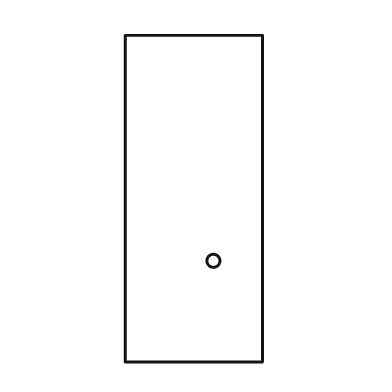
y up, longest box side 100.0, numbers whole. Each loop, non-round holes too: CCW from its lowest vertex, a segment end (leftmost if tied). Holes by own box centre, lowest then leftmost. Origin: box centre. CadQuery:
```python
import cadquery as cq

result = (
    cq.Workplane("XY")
    .moveTo(-21.0, -50.0)
    .lineTo(21.0, -50.0)
    .lineTo(21.0, 50.0)
    .lineTo(-21.0, 50.0)
    .close()
    .moveTo(6.0, -19.0)
    .circle(2.0)
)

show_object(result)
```